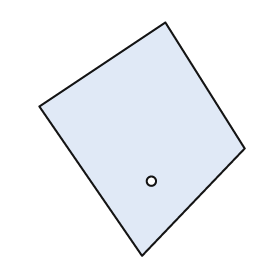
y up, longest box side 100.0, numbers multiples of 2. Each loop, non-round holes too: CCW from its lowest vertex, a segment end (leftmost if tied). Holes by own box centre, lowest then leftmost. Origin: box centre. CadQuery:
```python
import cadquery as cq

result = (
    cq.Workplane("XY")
    .moveTo(0.0, -50.0)
    .lineTo(44.0, -4.0)
    .lineTo(10.0, 50.0)
    .lineTo(-44.0, 14.0)
    .close()
    .moveTo(4.0, -18.0)
    .circle(2.0)
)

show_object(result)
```